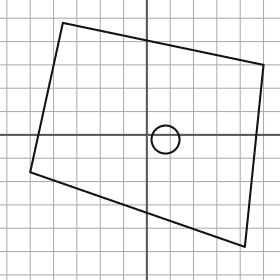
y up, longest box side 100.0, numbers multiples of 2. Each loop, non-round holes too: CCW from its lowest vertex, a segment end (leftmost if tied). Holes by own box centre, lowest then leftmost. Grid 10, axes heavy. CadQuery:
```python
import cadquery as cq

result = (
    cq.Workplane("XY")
    .moveTo(42.0, -48.0)
    .lineTo(50.0, 30.0)
    .lineTo(-36.0, 48.0)
    .lineTo(-50.0, -16.0)
    .close()
    .moveTo(8.0, -2.0)
    .circle(6.0)
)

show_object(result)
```